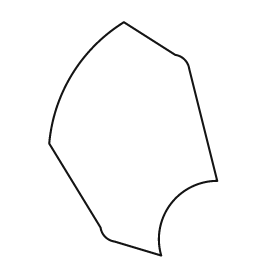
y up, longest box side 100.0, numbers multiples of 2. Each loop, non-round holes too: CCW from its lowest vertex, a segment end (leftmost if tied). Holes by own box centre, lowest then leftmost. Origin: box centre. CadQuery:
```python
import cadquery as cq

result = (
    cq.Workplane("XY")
    .moveTo(12.0, -50.0)
    .threePointArc((16.0, -28.0), (36.0, -18.0))
    .lineTo(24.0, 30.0)
    .threePointArc((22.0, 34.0), (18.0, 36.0))
    .lineTo(-4.0, 50.0)
    .threePointArc((-26.0, 28.0), (-36.0, -2.0))
    .lineTo(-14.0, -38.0)
    .threePointArc((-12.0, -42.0), (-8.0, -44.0))
    .close()
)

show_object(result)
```